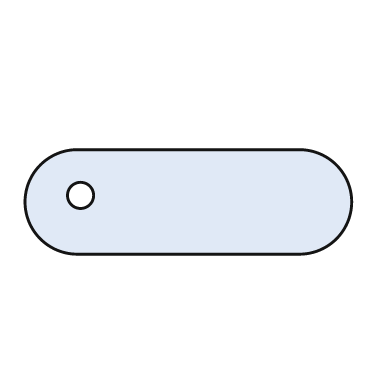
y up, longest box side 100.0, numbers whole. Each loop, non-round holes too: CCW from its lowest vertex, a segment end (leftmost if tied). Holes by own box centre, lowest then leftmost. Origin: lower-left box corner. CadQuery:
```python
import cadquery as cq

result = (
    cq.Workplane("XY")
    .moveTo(16.0, 0.0)
    .lineTo(84.0, 0.0)
    .threePointArc((100.0, 16.0), (84.0, 32.0))
    .lineTo(16.0, 32.0)
    .threePointArc((0.0, 16.0), (16.0, 0.0))
    .close()
    .moveTo(17.0, 18.0)
    .circle(4.0)
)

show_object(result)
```